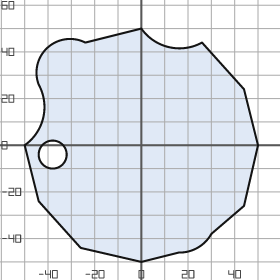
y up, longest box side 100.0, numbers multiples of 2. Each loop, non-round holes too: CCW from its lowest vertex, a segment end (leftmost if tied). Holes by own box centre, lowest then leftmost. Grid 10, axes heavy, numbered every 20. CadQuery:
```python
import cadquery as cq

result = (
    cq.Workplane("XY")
    .moveTo(0.0, -50.0)
    .lineTo(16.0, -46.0)
    .threePointArc((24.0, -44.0), (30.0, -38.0))
    .lineTo(44.0, -26.0)
    .lineTo(50.0, 0.0)
    .lineTo(44.0, 24.0)
    .lineTo(26.0, 44.0)
    .threePointArc((12.0, 42.0), (0.0, 50.0))
    .lineTo(-24.0, 44.0)
    .threePointArc((-40.0, 42.0), (-44.0, 26.0))
    .threePointArc((-42.0, 12.0), (-50.0, 0.0))
    .lineTo(-44.0, -24.0)
    .lineTo(-26.0, -44.0)
    .close()
    .moveTo(-38.0, -4.0)
    .circle(6.0)
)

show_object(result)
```